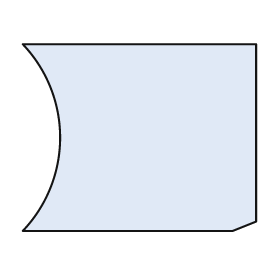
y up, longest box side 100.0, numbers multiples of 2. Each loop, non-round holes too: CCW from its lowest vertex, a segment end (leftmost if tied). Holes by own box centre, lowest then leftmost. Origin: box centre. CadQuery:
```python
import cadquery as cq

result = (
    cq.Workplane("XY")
    .moveTo(-50.0, -40.0)
    .lineTo(40.0, -40.0)
    .lineTo(50.0, -36.0)
    .lineTo(50.0, 40.0)
    .lineTo(-50.0, 40.0)
    .threePointArc((-34.0, 0.0), (-50.0, -40.0))
    .close()
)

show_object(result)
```